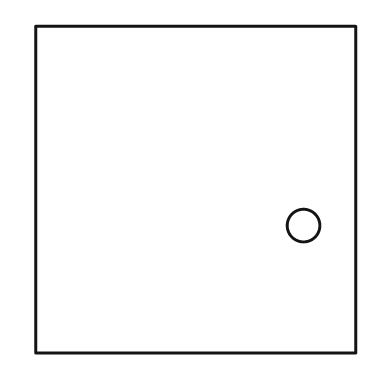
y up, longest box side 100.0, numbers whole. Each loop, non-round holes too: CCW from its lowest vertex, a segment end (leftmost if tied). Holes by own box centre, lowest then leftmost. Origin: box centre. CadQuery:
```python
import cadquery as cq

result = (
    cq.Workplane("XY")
    .moveTo(-49.0, -50.0)
    .lineTo(49.0, -50.0)
    .lineTo(49.0, 50.0)
    .lineTo(-49.0, 50.0)
    .close()
    .moveTo(33.0, -11.0)
    .circle(5.0)
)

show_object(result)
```